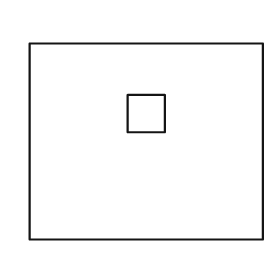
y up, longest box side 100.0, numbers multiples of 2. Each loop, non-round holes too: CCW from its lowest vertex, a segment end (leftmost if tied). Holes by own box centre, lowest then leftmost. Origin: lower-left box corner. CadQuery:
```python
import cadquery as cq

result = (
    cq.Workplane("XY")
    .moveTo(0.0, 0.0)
    .lineTo(100.0, 0.0)
    .lineTo(100.0, 84.0)
    .lineTo(0.0, 84.0)
    .close()
    .moveTo(42.0, 46.0)
    .lineTo(58.0, 46.0)
    .lineTo(58.0, 62.0)
    .lineTo(42.0, 62.0)
    .close()
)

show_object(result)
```